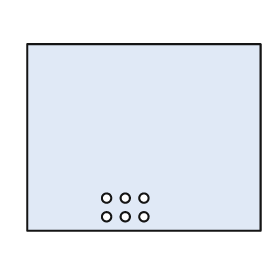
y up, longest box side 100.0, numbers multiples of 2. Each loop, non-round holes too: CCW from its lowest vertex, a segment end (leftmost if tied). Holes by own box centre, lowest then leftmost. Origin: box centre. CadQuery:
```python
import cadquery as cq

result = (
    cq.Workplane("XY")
    .moveTo(-50.0, -40.0)
    .lineTo(50.0, -40.0)
    .lineTo(50.0, 40.0)
    .lineTo(-50.0, 40.0)
    .close()
    .moveTo(-16.0, -34.0)
    .circle(2.0)
    .moveTo(-8.0, -34.0)
    .circle(2.0)
    .moveTo(0.0, -34.0)
    .circle(2.0)
    .moveTo(-16.0, -26.0)
    .circle(2.0)
    .moveTo(-8.0, -26.0)
    .circle(2.0)
    .moveTo(0.0, -26.0)
    .circle(2.0)
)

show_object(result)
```